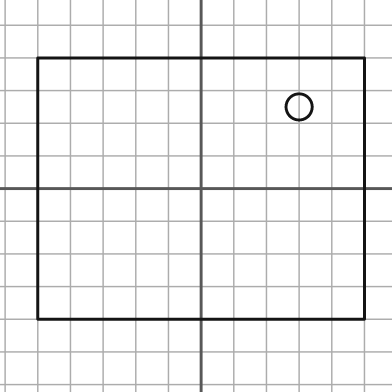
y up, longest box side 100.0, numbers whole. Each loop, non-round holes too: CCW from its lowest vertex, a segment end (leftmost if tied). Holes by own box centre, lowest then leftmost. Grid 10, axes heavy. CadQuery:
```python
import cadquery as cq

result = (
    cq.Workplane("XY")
    .moveTo(-50.0, -40.0)
    .lineTo(50.0, -40.0)
    .lineTo(50.0, 40.0)
    .lineTo(-50.0, 40.0)
    .close()
    .moveTo(30.0, 25.0)
    .circle(4.0)
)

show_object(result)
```